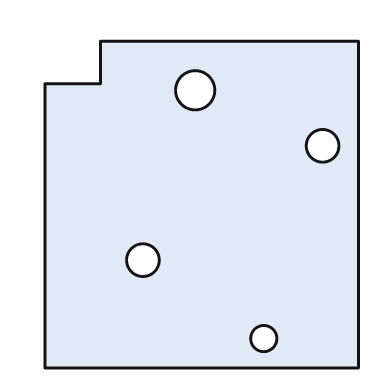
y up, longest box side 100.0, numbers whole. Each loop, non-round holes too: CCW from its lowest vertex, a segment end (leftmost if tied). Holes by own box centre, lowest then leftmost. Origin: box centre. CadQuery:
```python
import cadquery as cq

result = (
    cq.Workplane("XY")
    .moveTo(-48.0, -50.0)
    .lineTo(48.0, -50.0)
    .lineTo(48.0, 50.0)
    .lineTo(-31.0, 50.0)
    .lineTo(-31.0, 37.0)
    .lineTo(-48.0, 37.0)
    .close()
    .moveTo(19.0, -41.0)
    .circle(4.0)
    .moveTo(-18.0, -17.0)
    .circle(5.0)
    .moveTo(37.0, 18.0)
    .circle(5.0)
    .moveTo(-2.0, 35.0)
    .circle(6.0)
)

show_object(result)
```